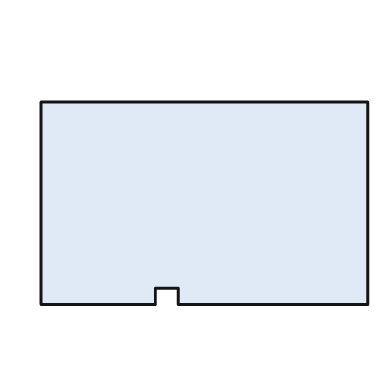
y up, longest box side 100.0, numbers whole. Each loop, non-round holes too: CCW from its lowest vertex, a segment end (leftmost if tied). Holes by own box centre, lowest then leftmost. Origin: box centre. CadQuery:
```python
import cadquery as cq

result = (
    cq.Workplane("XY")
    .moveTo(-50.0, -31.0)
    .lineTo(-15.0, -31.0)
    .lineTo(-15.0, -26.0)
    .lineTo(-8.0, -26.0)
    .lineTo(-8.0, -31.0)
    .lineTo(50.0, -31.0)
    .lineTo(50.0, 31.0)
    .lineTo(-50.0, 31.0)
    .close()
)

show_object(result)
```